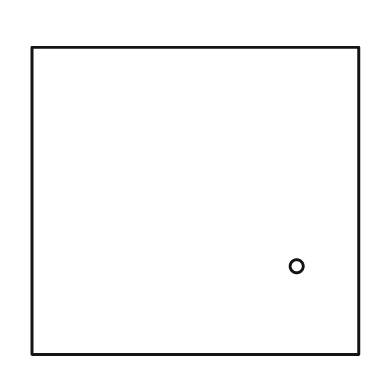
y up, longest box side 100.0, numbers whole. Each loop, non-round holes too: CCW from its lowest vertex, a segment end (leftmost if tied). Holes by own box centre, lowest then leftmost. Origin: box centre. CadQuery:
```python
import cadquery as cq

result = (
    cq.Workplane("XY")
    .moveTo(-50.0, -47.0)
    .lineTo(50.0, -47.0)
    .lineTo(50.0, 47.0)
    .lineTo(-50.0, 47.0)
    .close()
    .moveTo(31.0, -20.0)
    .circle(2.0)
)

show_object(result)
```